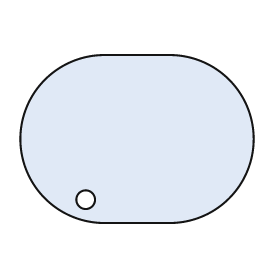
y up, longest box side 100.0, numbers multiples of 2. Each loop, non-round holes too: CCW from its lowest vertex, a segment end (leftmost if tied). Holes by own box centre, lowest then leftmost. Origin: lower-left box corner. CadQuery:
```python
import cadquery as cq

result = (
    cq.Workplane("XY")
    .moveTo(36.0, 0.0)
    .lineTo(64.0, 0.0)
    .threePointArc((100.0, 36.0), (64.0, 72.0))
    .lineTo(36.0, 72.0)
    .threePointArc((0.0, 36.0), (36.0, 0.0))
    .close()
    .moveTo(28.0, 10.0)
    .circle(4.0)
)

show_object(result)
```